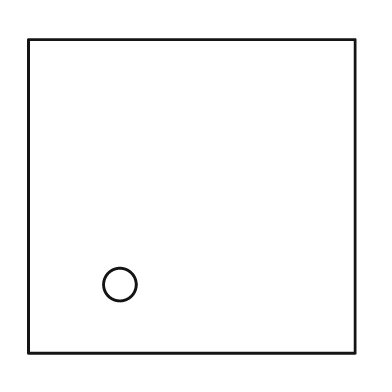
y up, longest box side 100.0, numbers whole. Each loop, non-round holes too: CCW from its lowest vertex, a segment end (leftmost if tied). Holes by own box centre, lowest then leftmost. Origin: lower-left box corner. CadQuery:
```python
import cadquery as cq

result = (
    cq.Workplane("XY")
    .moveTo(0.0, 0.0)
    .lineTo(100.0, 0.0)
    .lineTo(100.0, 96.0)
    .lineTo(0.0, 96.0)
    .close()
    .moveTo(28.0, 21.0)
    .circle(5.0)
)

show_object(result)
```